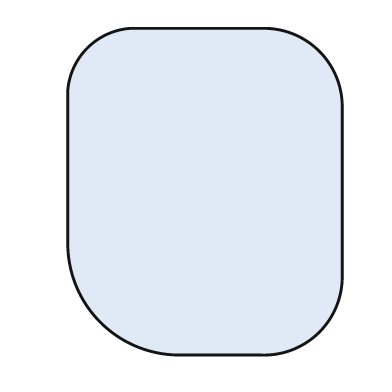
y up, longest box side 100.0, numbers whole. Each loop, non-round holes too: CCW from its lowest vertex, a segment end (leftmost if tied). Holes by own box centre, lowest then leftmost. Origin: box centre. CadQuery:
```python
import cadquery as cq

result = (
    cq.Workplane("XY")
    .moveTo(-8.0, -50.0)
    .lineTo(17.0, -50.0)
    .threePointArc((35.0, -43.0), (42.0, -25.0))
    .lineTo(42.0, 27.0)
    .threePointArc((35.0, 43.0), (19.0, 50.0))
    .lineTo(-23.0, 50.0)
    .threePointArc((-36.0, 44.0), (-42.0, 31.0))
    .lineTo(-42.0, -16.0)
    .threePointArc((-32.0, -40.0), (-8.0, -50.0))
    .close()
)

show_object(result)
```